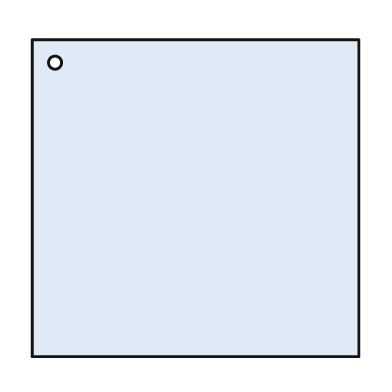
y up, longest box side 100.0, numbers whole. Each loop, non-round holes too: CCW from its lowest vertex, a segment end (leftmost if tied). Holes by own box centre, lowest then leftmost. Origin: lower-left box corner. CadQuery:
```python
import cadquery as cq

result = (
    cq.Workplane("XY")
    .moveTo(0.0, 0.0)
    .lineTo(100.0, 0.0)
    .lineTo(100.0, 97.0)
    .lineTo(0.0, 97.0)
    .close()
    .moveTo(7.0, 90.0)
    .circle(2.0)
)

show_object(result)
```